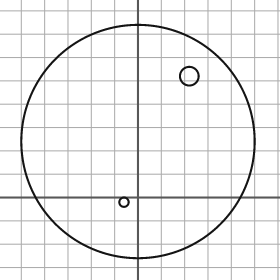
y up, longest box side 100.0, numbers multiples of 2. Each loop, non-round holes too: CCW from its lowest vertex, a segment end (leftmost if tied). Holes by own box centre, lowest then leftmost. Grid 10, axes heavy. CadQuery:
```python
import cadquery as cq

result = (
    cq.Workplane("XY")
    .moveTo(0.0, 24.0)
    .circle(50.0)
    .moveTo(-6.0, -2.0)
    .circle(2.0)
    .moveTo(22.0, 52.0)
    .circle(4.0)
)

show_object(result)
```